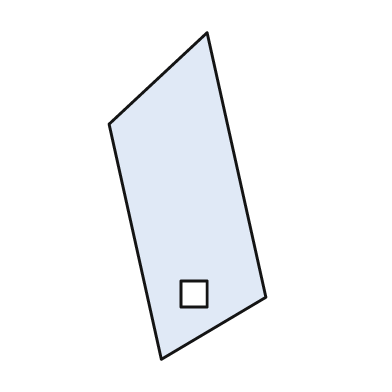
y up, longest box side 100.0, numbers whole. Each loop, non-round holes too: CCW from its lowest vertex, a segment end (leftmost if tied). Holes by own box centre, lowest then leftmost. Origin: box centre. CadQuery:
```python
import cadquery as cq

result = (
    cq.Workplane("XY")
    .moveTo(-8.0, -50.0)
    .lineTo(24.0, -31.0)
    .lineTo(6.0, 50.0)
    .lineTo(-24.0, 22.0)
    .close()
    .moveTo(-2.0, -34.0)
    .lineTo(6.0, -34.0)
    .lineTo(6.0, -26.0)
    .lineTo(-2.0, -26.0)
    .close()
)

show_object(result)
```